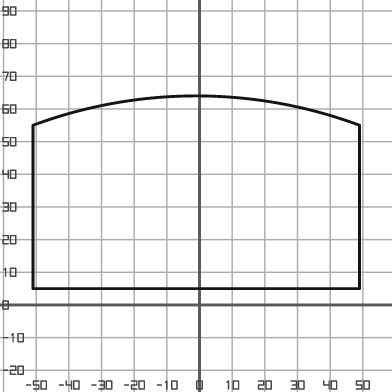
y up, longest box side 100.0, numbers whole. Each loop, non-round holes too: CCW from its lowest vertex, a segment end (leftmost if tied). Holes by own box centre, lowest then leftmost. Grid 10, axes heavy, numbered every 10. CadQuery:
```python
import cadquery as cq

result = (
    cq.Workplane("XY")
    .moveTo(-51.0, 5.0)
    .lineTo(49.0, 5.0)
    .lineTo(49.0, 55.0)
    .threePointArc((-1.0, 64.0), (-51.0, 55.0))
    .close()
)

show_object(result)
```